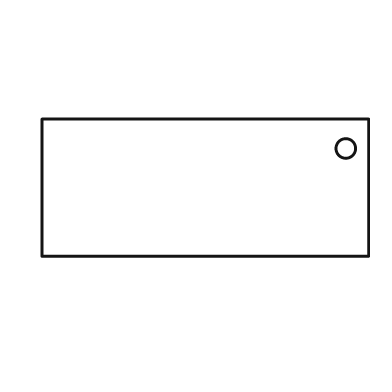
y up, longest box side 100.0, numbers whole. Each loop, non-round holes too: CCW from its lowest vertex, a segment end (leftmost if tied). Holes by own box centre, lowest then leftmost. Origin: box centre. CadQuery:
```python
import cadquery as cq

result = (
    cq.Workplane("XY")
    .moveTo(-50.0, -21.0)
    .lineTo(50.0, -21.0)
    .lineTo(50.0, 21.0)
    .lineTo(-50.0, 21.0)
    .close()
    .moveTo(43.0, 12.0)
    .circle(3.0)
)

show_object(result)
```